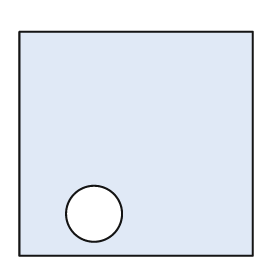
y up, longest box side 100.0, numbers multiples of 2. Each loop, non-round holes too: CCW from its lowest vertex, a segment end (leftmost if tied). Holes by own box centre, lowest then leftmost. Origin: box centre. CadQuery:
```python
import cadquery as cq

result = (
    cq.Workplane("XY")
    .moveTo(-50.0, -48.0)
    .lineTo(50.0, -48.0)
    .lineTo(50.0, 48.0)
    .lineTo(-50.0, 48.0)
    .close()
    .moveTo(-18.0, -30.0)
    .circle(12.0)
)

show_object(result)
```